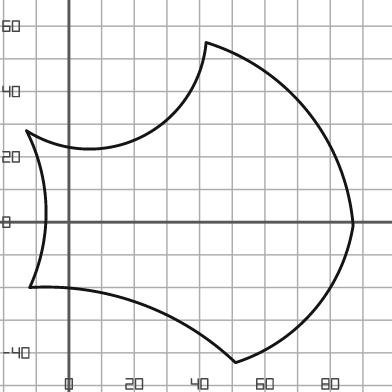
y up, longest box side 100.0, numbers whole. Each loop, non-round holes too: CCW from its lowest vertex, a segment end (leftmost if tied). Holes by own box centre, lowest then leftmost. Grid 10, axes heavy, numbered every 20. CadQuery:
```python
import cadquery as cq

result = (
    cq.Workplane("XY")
    .moveTo(51.0, -43.0)
    .threePointArc((75.0, -27.0), (87.0, -1.0))
    .threePointArc((73.0, 34.0), (42.0, 55.0))
    .threePointArc((22.0, 26.0), (-13.0, 28.0))
    .threePointArc((-7.0, 4.0), (-12.0, -20.0))
    .threePointArc((22.0, -25.0), (51.0, -43.0))
    .close()
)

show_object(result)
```